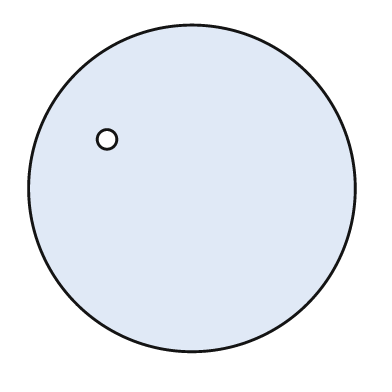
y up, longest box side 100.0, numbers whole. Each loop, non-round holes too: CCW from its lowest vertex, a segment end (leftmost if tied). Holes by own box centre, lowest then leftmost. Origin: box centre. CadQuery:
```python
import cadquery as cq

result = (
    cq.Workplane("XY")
    .moveTo(0.0, 0.0)
    .circle(50.0)
    .moveTo(-26.0, 15.0)
    .circle(3.0)
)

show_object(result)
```